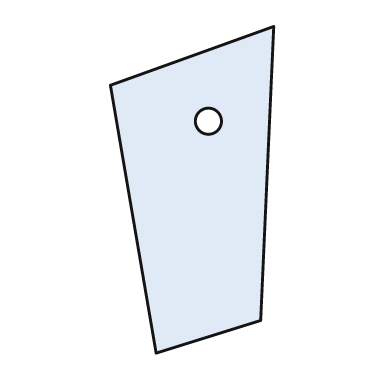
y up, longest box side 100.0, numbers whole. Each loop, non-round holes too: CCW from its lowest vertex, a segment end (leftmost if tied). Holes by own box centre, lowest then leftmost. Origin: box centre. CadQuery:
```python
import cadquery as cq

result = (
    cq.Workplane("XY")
    .moveTo(-11.0, -50.0)
    .lineTo(21.0, -40.0)
    .lineTo(25.0, 50.0)
    .lineTo(-25.0, 32.0)
    .close()
    .moveTo(5.0, 21.0)
    .circle(4.0)
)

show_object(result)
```